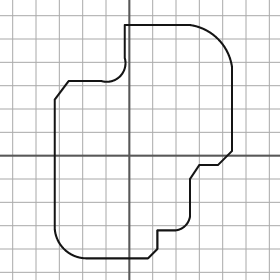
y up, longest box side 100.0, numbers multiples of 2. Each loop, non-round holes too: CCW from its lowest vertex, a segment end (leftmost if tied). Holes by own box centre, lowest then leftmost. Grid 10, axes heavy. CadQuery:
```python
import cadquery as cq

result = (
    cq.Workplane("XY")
    .moveTo(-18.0, -44.0)
    .lineTo(8.0, -44.0)
    .lineTo(12.0, -40.0)
    .lineTo(12.0, -32.0)
    .lineTo(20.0, -32.0)
    .threePointArc((24.0, -30.0), (26.0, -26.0))
    .lineTo(26.0, -10.0)
    .lineTo(30.0, -4.0)
    .lineTo(38.0, -4.0)
    .lineTo(44.0, 2.0)
    .lineTo(44.0, 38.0)
    .threePointArc((38.0, 50.0), (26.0, 56.0))
    .lineTo(-2.0, 56.0)
    .lineTo(-2.0, 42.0)
    .threePointArc((-4.0, 34.0), (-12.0, 32.0))
    .lineTo(-26.0, 32.0)
    .lineTo(-32.0, 24.0)
    .lineTo(-32.0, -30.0)
    .threePointArc((-28.0, -40.0), (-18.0, -44.0))
    .close()
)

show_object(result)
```